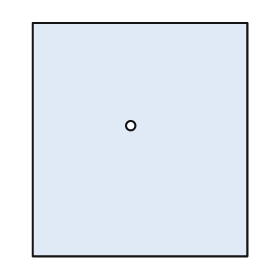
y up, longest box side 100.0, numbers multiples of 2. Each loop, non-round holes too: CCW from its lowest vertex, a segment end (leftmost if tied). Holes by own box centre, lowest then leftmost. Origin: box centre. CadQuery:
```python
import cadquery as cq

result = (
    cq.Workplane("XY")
    .moveTo(-46.0, -50.0)
    .lineTo(46.0, -50.0)
    .lineTo(46.0, 50.0)
    .lineTo(-46.0, 50.0)
    .close()
    .moveTo(-4.0, 6.0)
    .circle(2.0)
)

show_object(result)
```